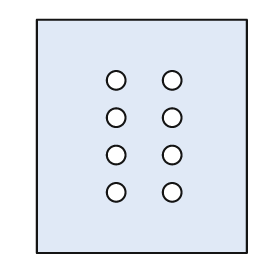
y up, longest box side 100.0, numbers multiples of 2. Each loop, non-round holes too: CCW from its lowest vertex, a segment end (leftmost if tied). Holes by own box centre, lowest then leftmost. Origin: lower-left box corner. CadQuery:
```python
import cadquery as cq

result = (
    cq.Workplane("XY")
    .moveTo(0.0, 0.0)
    .lineTo(90.0, 0.0)
    .lineTo(90.0, 100.0)
    .lineTo(0.0, 100.0)
    .close()
    .moveTo(34.0, 26.0)
    .circle(4.0)
    .moveTo(58.0, 26.0)
    .circle(4.0)
    .moveTo(34.0, 42.0)
    .circle(4.0)
    .moveTo(58.0, 42.0)
    .circle(4.0)
    .moveTo(34.0, 58.0)
    .circle(4.0)
    .moveTo(58.0, 58.0)
    .circle(4.0)
    .moveTo(34.0, 74.0)
    .circle(4.0)
    .moveTo(58.0, 74.0)
    .circle(4.0)
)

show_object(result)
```